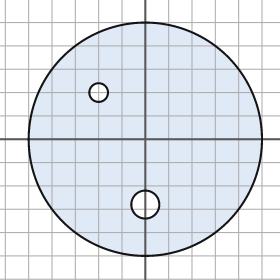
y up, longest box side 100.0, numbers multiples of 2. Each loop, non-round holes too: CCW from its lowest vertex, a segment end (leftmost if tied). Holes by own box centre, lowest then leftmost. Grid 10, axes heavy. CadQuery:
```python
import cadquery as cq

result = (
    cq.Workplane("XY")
    .moveTo(0.0, 0.0)
    .circle(50.0)
    .moveTo(0.0, -28.0)
    .circle(6.0)
    .moveTo(-20.0, 20.0)
    .circle(4.0)
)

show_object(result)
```